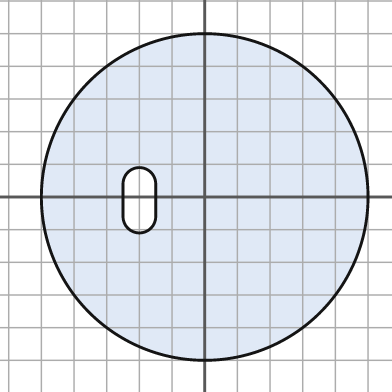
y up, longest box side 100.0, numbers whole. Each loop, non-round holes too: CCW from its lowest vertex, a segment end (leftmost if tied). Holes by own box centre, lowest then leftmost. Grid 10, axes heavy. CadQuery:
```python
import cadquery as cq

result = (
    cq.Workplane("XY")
    .moveTo(0.0, 0.0)
    .circle(50.0)
    .moveTo(-25.0, -6.0)
    .threePointArc((-20.0, -11.0), (-15.0, -6.0))
    .lineTo(-15.0, 4.0)
    .threePointArc((-20.0, 9.0), (-25.0, 4.0))
    .close()
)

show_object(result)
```